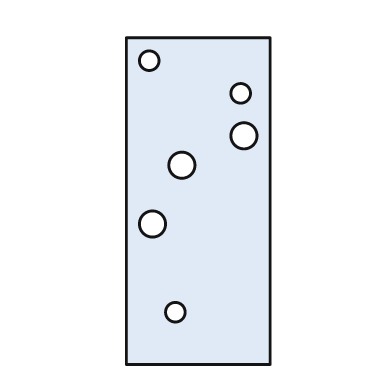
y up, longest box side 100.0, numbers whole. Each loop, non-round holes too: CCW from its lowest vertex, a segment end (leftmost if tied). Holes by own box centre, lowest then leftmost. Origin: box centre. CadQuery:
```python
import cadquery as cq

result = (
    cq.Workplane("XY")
    .moveTo(-22.0, -50.0)
    .lineTo(22.0, -50.0)
    .lineTo(22.0, 50.0)
    .lineTo(-22.0, 50.0)
    .close()
    .moveTo(-7.0, -34.0)
    .circle(3.0)
    .moveTo(-14.0, -7.0)
    .circle(4.0)
    .moveTo(-5.0, 11.0)
    .circle(4.0)
    .moveTo(14.0, 20.0)
    .circle(4.0)
    .moveTo(13.0, 33.0)
    .circle(3.0)
    .moveTo(-15.0, 43.0)
    .circle(3.0)
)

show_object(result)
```